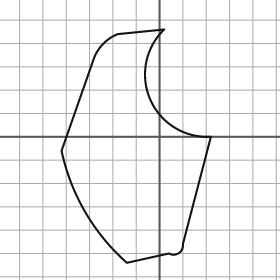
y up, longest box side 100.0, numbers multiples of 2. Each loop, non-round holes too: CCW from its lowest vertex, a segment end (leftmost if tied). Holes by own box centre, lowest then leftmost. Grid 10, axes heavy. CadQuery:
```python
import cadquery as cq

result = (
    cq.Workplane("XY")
    .moveTo(-14.0, -54.0)
    .lineTo(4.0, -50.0)
    .threePointArc((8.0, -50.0), (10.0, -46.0))
    .lineTo(22.0, 0.0)
    .threePointArc((-4.0, 16.0), (2.0, 46.0))
    .lineTo(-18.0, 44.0)
    .threePointArc((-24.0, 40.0), (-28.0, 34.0))
    .lineTo(-42.0, -6.0)
    .threePointArc((-32.0, -32.0), (-14.0, -54.0))
    .close()
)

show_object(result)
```